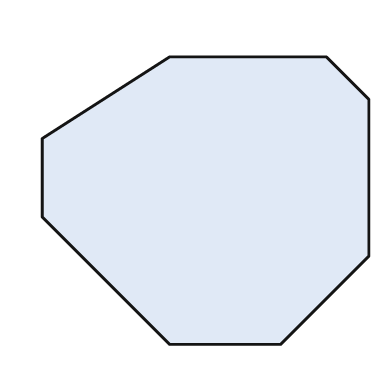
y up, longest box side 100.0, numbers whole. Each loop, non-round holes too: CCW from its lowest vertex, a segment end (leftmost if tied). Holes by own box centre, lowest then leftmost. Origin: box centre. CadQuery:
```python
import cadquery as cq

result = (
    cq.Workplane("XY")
    .moveTo(-11.0, -44.0)
    .lineTo(23.0, -44.0)
    .lineTo(50.0, -17.0)
    .lineTo(50.0, 31.0)
    .lineTo(37.0, 44.0)
    .lineTo(-11.0, 44.0)
    .lineTo(-50.0, 19.0)
    .lineTo(-50.0, -5.0)
    .close()
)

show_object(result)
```